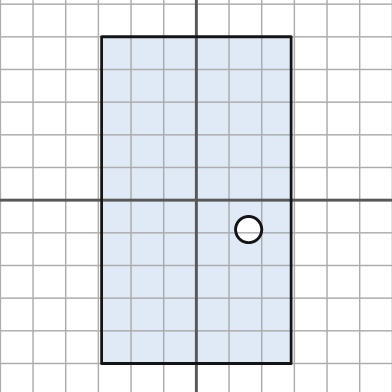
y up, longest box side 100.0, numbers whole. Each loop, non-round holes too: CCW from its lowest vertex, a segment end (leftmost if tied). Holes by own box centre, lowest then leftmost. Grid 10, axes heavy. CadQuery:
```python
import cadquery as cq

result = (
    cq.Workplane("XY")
    .moveTo(-29.0, -50.0)
    .lineTo(29.0, -50.0)
    .lineTo(29.0, 50.0)
    .lineTo(-29.0, 50.0)
    .close()
    .moveTo(16.0, -9.0)
    .circle(4.0)
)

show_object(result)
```